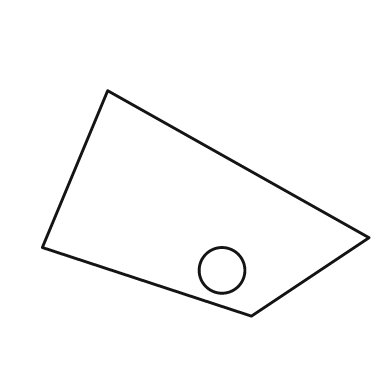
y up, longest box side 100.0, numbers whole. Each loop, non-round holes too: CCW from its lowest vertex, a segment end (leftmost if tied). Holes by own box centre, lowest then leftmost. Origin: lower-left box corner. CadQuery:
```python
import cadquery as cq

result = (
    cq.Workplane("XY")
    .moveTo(64.0, 0.0)
    .lineTo(100.0, 24.0)
    .lineTo(20.0, 69.0)
    .lineTo(0.0, 21.0)
    .close()
    .moveTo(55.0, 14.0)
    .circle(7.0)
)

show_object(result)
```